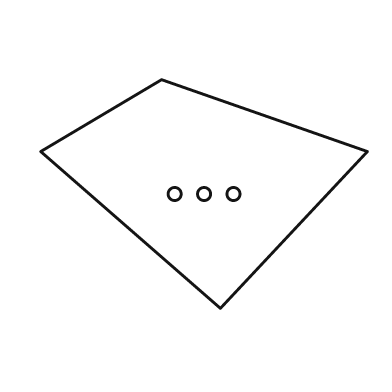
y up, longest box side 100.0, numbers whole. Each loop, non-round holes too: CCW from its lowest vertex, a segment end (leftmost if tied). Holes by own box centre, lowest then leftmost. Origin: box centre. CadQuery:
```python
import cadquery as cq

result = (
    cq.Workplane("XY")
    .moveTo(5.0, -35.0)
    .lineTo(50.0, 13.0)
    .lineTo(-13.0, 35.0)
    .lineTo(-50.0, 13.0)
    .close()
    .moveTo(-9.0, 0.0)
    .circle(2.0)
    .moveTo(0.0, 0.0)
    .circle(2.0)
    .moveTo(9.0, 0.0)
    .circle(2.0)
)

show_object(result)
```